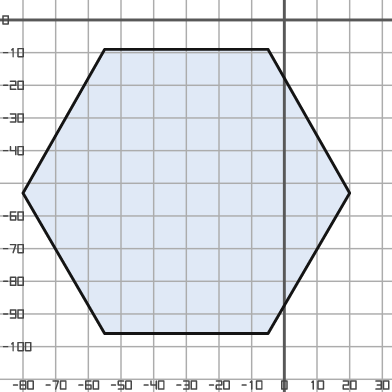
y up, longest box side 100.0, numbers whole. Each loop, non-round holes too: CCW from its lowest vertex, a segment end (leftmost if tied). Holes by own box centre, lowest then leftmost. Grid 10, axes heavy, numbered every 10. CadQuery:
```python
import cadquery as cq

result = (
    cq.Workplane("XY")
    .moveTo(-55.0, -96.0)
    .lineTo(-5.0, -96.0)
    .lineTo(20.0, -53.0)
    .lineTo(-5.0, -9.0)
    .lineTo(-55.0, -9.0)
    .lineTo(-80.0, -53.0)
    .close()
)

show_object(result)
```